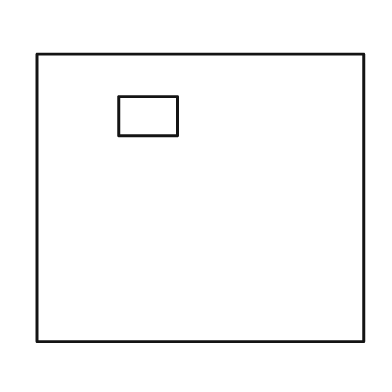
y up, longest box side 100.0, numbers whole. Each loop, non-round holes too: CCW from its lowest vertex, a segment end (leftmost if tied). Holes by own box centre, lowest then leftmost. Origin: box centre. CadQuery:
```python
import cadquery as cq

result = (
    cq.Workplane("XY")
    .moveTo(-50.0, -44.0)
    .lineTo(50.0, -44.0)
    .lineTo(50.0, 44.0)
    .lineTo(-50.0, 44.0)
    .close()
    .moveTo(-25.0, 19.0)
    .lineTo(-7.0, 19.0)
    .lineTo(-7.0, 31.0)
    .lineTo(-25.0, 31.0)
    .close()
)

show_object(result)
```